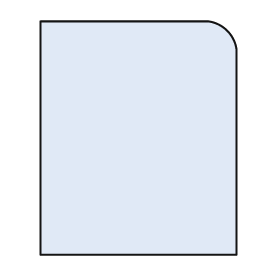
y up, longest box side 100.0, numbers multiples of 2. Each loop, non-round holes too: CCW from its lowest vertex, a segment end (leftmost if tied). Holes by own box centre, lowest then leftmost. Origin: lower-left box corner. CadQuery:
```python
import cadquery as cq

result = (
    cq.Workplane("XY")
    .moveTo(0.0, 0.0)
    .lineTo(84.0, 0.0)
    .lineTo(84.0, 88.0)
    .threePointArc((80.0, 96.0), (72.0, 100.0))
    .lineTo(0.0, 100.0)
    .close()
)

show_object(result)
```